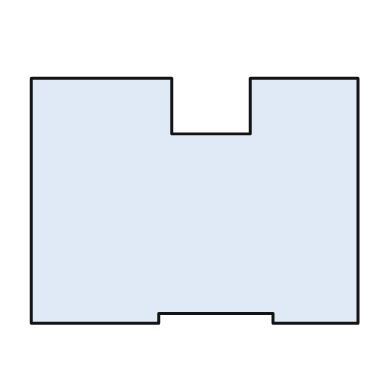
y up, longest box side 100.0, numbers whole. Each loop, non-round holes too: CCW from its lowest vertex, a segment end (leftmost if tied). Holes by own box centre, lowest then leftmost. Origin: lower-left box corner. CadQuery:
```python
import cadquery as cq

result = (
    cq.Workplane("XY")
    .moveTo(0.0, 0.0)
    .lineTo(39.0, 0.0)
    .lineTo(39.0, 3.0)
    .lineTo(74.0, 3.0)
    .lineTo(74.0, 0.0)
    .lineTo(100.0, 0.0)
    .lineTo(100.0, 75.0)
    .lineTo(67.0, 75.0)
    .lineTo(67.0, 58.0)
    .lineTo(43.0, 58.0)
    .lineTo(43.0, 75.0)
    .lineTo(0.0, 75.0)
    .close()
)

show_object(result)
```